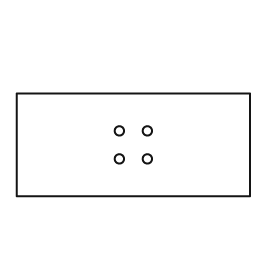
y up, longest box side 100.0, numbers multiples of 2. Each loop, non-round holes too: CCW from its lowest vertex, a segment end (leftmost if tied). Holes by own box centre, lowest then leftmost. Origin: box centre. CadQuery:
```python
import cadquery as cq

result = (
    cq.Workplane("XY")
    .moveTo(-50.0, -22.0)
    .lineTo(50.0, -22.0)
    .lineTo(50.0, 22.0)
    .lineTo(-50.0, 22.0)
    .close()
    .moveTo(-6.0, -6.0)
    .circle(2.0)
    .moveTo(6.0, -6.0)
    .circle(2.0)
    .moveTo(-6.0, 6.0)
    .circle(2.0)
    .moveTo(6.0, 6.0)
    .circle(2.0)
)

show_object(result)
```